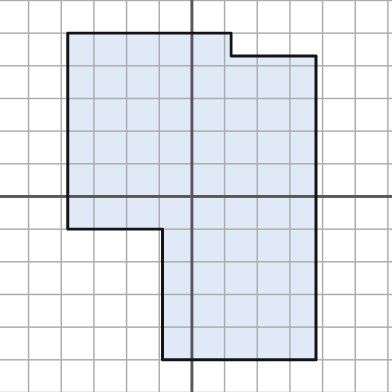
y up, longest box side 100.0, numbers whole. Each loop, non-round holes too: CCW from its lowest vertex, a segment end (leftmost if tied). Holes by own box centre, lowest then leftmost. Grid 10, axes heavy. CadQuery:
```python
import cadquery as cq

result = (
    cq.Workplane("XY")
    .moveTo(-9.0, -50.0)
    .lineTo(38.0, -50.0)
    .lineTo(38.0, 43.0)
    .lineTo(12.0, 43.0)
    .lineTo(12.0, 50.0)
    .lineTo(-38.0, 50.0)
    .lineTo(-38.0, -10.0)
    .lineTo(-9.0, -10.0)
    .close()
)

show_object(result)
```